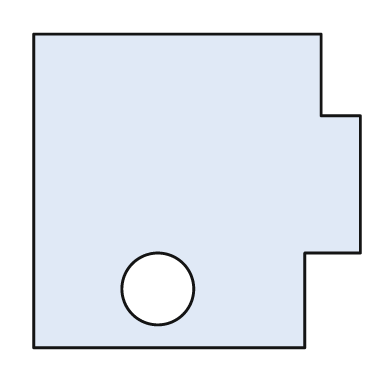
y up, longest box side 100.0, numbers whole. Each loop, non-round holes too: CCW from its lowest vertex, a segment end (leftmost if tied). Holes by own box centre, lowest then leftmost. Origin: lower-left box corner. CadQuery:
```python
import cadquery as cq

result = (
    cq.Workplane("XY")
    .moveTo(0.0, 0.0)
    .lineTo(83.0, 0.0)
    .lineTo(83.0, 29.0)
    .lineTo(100.0, 29.0)
    .lineTo(100.0, 71.0)
    .lineTo(88.0, 71.0)
    .lineTo(88.0, 96.0)
    .lineTo(0.0, 96.0)
    .close()
    .moveTo(38.0, 18.0)
    .circle(11.0)
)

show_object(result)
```